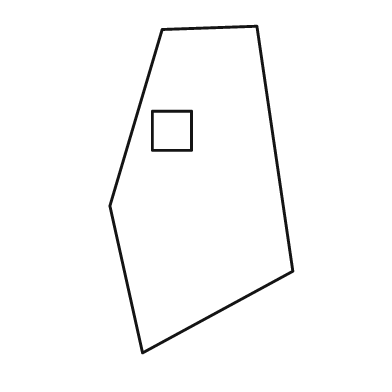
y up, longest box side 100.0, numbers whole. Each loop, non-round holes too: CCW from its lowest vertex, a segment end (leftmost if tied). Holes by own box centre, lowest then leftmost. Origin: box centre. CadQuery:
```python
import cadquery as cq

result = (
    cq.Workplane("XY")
    .moveTo(-18.0, -50.0)
    .lineTo(28.0, -25.0)
    .lineTo(17.0, 50.0)
    .lineTo(-12.0, 49.0)
    .lineTo(-28.0, -5.0)
    .close()
    .moveTo(-15.0, 12.0)
    .lineTo(-3.0, 12.0)
    .lineTo(-3.0, 24.0)
    .lineTo(-15.0, 24.0)
    .close()
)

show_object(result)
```